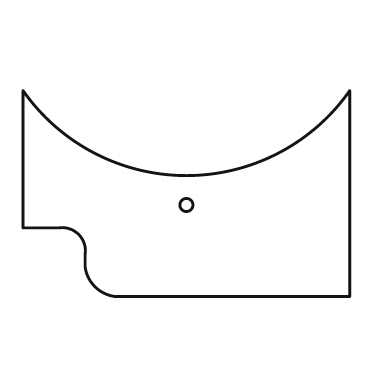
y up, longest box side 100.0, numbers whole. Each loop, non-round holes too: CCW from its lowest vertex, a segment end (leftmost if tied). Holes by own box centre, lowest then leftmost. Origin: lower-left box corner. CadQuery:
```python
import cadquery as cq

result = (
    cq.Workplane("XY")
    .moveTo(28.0, 0.0)
    .lineTo(100.0, 0.0)
    .lineTo(100.0, 63.0)
    .threePointArc((50.0, 37.0), (0.0, 63.0))
    .lineTo(0.0, 21.0)
    .lineTo(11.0, 21.0)
    .threePointArc((17.0, 19.0), (19.0, 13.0))
    .lineTo(19.0, 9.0)
    .threePointArc((22.0, 3.0), (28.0, 0.0))
    .close()
    .moveTo(50.0, 28.0)
    .circle(2.0)
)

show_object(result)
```